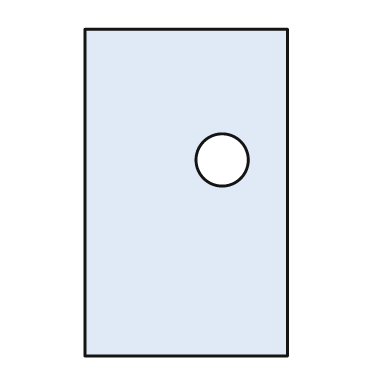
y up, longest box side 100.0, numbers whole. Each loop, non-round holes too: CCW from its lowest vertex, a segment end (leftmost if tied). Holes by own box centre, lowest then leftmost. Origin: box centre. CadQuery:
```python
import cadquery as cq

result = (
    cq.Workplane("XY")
    .moveTo(-31.0, -50.0)
    .lineTo(31.0, -50.0)
    .lineTo(31.0, 50.0)
    .lineTo(-31.0, 50.0)
    .close()
    .moveTo(11.0, 10.0)
    .circle(8.0)
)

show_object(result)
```